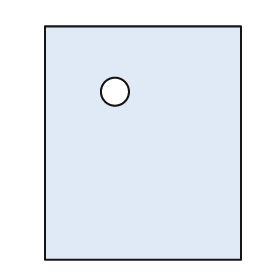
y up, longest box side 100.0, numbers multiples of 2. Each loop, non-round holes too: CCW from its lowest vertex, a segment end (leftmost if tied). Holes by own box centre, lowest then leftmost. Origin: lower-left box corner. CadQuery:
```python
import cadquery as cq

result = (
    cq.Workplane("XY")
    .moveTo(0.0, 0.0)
    .lineTo(84.0, 0.0)
    .lineTo(84.0, 100.0)
    .lineTo(0.0, 100.0)
    .close()
    .moveTo(30.0, 72.0)
    .circle(6.0)
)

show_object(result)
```